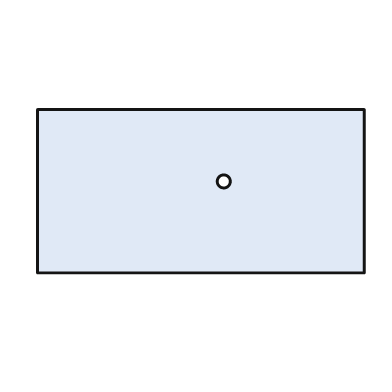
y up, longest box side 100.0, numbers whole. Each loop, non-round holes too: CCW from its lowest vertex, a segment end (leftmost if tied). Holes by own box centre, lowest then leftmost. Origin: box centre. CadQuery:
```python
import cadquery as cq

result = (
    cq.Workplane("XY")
    .moveTo(-50.0, -25.0)
    .lineTo(50.0, -25.0)
    .lineTo(50.0, 25.0)
    .lineTo(-50.0, 25.0)
    .close()
    .moveTo(7.0, 3.0)
    .circle(2.0)
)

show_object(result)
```